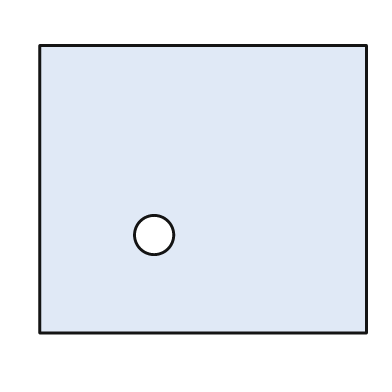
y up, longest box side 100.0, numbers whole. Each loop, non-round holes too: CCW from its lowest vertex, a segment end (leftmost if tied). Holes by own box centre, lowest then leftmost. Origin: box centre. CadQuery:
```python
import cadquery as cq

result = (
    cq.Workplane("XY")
    .moveTo(-50.0, -44.0)
    .lineTo(50.0, -44.0)
    .lineTo(50.0, 44.0)
    .lineTo(-50.0, 44.0)
    .close()
    .moveTo(-15.0, -14.0)
    .circle(6.0)
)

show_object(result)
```